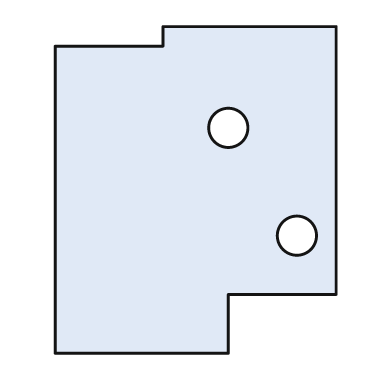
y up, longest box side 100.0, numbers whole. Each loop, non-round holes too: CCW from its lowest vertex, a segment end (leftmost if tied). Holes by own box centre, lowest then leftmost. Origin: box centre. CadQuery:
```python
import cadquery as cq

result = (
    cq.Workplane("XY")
    .moveTo(-43.0, -50.0)
    .lineTo(10.0, -50.0)
    .lineTo(10.0, -32.0)
    .lineTo(43.0, -32.0)
    .lineTo(43.0, 50.0)
    .lineTo(-10.0, 50.0)
    .lineTo(-10.0, 44.0)
    .lineTo(-43.0, 44.0)
    .close()
    .moveTo(31.0, -14.0)
    .circle(6.0)
    .moveTo(10.0, 19.0)
    .circle(6.0)
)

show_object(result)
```